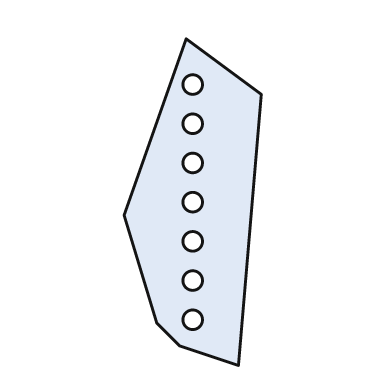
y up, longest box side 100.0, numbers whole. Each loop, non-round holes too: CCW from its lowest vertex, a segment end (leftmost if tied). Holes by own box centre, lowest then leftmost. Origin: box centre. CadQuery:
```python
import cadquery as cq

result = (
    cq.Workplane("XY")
    .moveTo(14.0, -50.0)
    .lineTo(21.0, 33.0)
    .lineTo(-2.0, 50.0)
    .lineTo(-21.0, -4.0)
    .lineTo(-11.0, -37.0)
    .lineTo(-4.0, -44.0)
    .close()
    .moveTo(0.0, -36.0)
    .circle(3.0)
    .moveTo(0.0, -24.0)
    .circle(3.0)
    .moveTo(0.0, -12.0)
    .circle(3.0)
    .moveTo(0.0, 0.0)
    .circle(3.0)
    .moveTo(0.0, 12.0)
    .circle(3.0)
    .moveTo(0.0, 24.0)
    .circle(3.0)
    .moveTo(0.0, 36.0)
    .circle(3.0)
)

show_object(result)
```